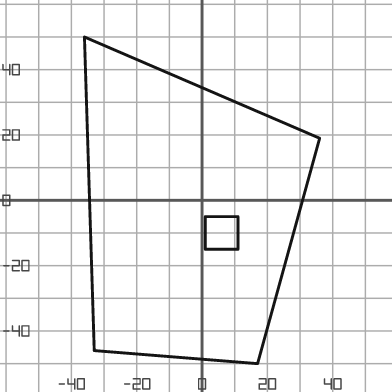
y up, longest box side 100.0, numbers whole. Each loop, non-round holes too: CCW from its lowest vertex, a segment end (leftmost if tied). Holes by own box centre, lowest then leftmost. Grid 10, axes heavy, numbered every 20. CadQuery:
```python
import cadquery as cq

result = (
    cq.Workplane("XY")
    .moveTo(17.0, -50.0)
    .lineTo(36.0, 19.0)
    .lineTo(-36.0, 50.0)
    .lineTo(-33.0, -46.0)
    .close()
    .moveTo(1.0, -15.0)
    .lineTo(11.0, -15.0)
    .lineTo(11.0, -5.0)
    .lineTo(1.0, -5.0)
    .close()
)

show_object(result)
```